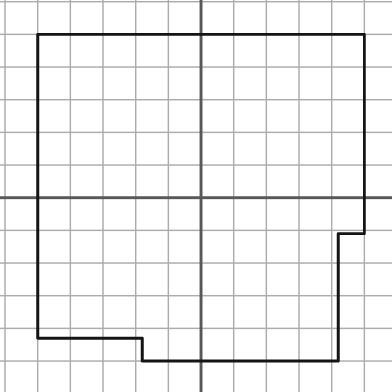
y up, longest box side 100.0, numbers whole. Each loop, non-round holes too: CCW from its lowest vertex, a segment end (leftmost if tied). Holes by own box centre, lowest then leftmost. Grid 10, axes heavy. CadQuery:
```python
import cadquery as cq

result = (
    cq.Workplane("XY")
    .moveTo(-18.0, -50.0)
    .lineTo(42.0, -50.0)
    .lineTo(42.0, -11.0)
    .lineTo(50.0, -11.0)
    .lineTo(50.0, 50.0)
    .lineTo(-50.0, 50.0)
    .lineTo(-50.0, -43.0)
    .lineTo(-18.0, -43.0)
    .close()
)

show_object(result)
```